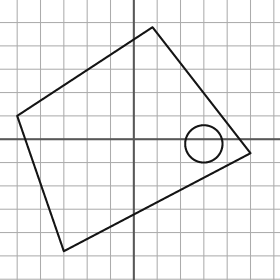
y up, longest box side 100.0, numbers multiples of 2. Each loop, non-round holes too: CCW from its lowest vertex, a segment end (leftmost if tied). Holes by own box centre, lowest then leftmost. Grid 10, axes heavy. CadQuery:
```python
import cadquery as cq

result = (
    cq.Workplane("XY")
    .moveTo(-30.0, -48.0)
    .lineTo(50.0, -6.0)
    .lineTo(8.0, 48.0)
    .lineTo(-50.0, 10.0)
    .close()
    .moveTo(30.0, -2.0)
    .circle(8.0)
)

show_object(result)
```